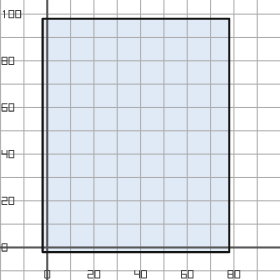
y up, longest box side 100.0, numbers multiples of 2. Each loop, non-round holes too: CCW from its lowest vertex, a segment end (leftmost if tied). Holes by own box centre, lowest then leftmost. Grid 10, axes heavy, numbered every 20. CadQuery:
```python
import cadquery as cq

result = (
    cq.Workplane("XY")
    .moveTo(-2.0, -2.0)
    .lineTo(78.0, -2.0)
    .lineTo(78.0, 98.0)
    .lineTo(-2.0, 98.0)
    .close()
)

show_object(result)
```